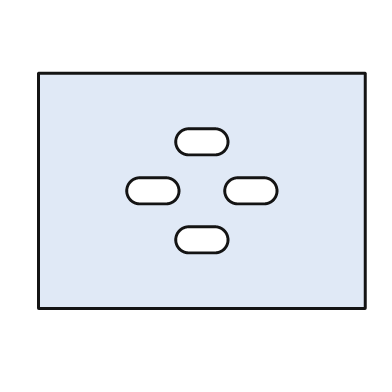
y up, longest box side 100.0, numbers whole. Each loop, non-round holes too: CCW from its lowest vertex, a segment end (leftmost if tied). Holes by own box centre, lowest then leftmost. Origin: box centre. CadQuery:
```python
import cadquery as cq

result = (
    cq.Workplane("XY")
    .moveTo(-50.0, -36.0)
    .lineTo(50.0, -36.0)
    .lineTo(50.0, 36.0)
    .lineTo(-50.0, 36.0)
    .close()
    .moveTo(-4.0, -19.0)
    .lineTo(4.0, -19.0)
    .threePointArc((8.0, -15.0), (4.0, -11.0))
    .lineTo(-4.0, -11.0)
    .threePointArc((-8.0, -15.0), (-4.0, -19.0))
    .close()
    .moveTo(-19.0, -4.0)
    .lineTo(-11.0, -4.0)
    .threePointArc((-7.0, 0.0), (-11.0, 4.0))
    .lineTo(-19.0, 4.0)
    .threePointArc((-23.0, 0.0), (-19.0, -4.0))
    .close()
    .moveTo(11.0, -4.0)
    .lineTo(19.0, -4.0)
    .threePointArc((23.0, 0.0), (19.0, 4.0))
    .lineTo(11.0, 4.0)
    .threePointArc((7.0, 0.0), (11.0, -4.0))
    .close()
    .moveTo(-4.0, 11.0)
    .lineTo(4.0, 11.0)
    .threePointArc((8.0, 15.0), (4.0, 19.0))
    .lineTo(-4.0, 19.0)
    .threePointArc((-8.0, 15.0), (-4.0, 11.0))
    .close()
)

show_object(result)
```